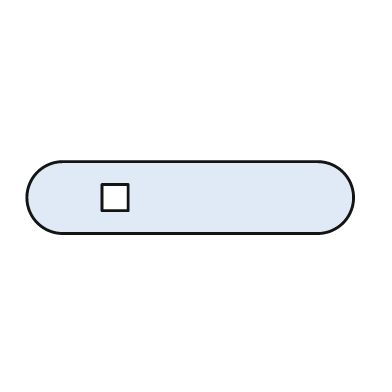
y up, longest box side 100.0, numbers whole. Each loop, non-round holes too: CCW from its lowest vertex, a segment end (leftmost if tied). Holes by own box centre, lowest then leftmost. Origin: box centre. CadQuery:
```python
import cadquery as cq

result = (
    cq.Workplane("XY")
    .moveTo(-39.0, -11.0)
    .lineTo(39.0, -11.0)
    .threePointArc((50.0, 0.0), (39.0, 11.0))
    .lineTo(-39.0, 11.0)
    .threePointArc((-50.0, 0.0), (-39.0, -11.0))
    .close()
    .moveTo(-27.0, -4.0)
    .lineTo(-19.0, -4.0)
    .lineTo(-19.0, 4.0)
    .lineTo(-27.0, 4.0)
    .close()
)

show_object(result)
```